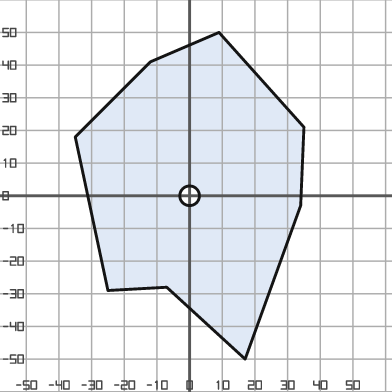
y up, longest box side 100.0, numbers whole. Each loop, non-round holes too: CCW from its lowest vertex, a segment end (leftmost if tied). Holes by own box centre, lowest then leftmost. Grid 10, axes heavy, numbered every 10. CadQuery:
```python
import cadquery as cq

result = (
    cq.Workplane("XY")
    .moveTo(17.0, -50.0)
    .lineTo(34.0, -3.0)
    .lineTo(35.0, 21.0)
    .lineTo(9.0, 50.0)
    .lineTo(-12.0, 41.0)
    .lineTo(-35.0, 18.0)
    .lineTo(-25.0, -29.0)
    .lineTo(-7.0, -28.0)
    .close()
    .moveTo(0.0, 0.0)
    .circle(3.0)
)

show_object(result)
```